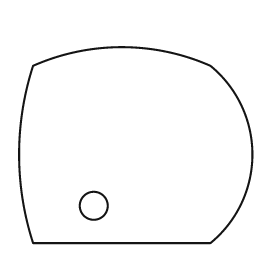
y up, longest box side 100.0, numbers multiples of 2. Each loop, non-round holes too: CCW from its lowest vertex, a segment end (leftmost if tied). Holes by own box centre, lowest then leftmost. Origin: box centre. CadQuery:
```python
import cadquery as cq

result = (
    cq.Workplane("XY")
    .moveTo(-44.0, -42.0)
    .lineTo(32.0, -42.0)
    .threePointArc((50.0, -4.0), (32.0, 34.0))
    .threePointArc((-6.0, 42.0), (-44.0, 34.0))
    .threePointArc((-50.0, -4.0), (-44.0, -42.0))
    .close()
    .moveTo(-18.0, -26.0)
    .circle(6.0)
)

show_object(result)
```